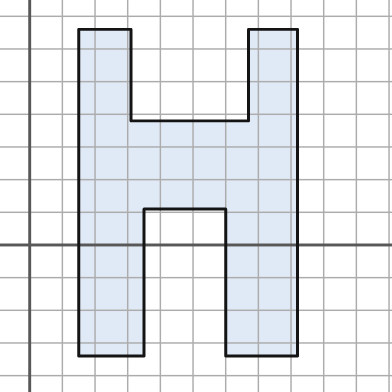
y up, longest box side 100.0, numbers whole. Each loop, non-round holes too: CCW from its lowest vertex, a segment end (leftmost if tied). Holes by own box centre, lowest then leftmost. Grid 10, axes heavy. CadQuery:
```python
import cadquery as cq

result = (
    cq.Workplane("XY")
    .moveTo(15.0, -34.0)
    .lineTo(35.0, -34.0)
    .lineTo(35.0, 11.0)
    .lineTo(60.0, 11.0)
    .lineTo(60.0, -34.0)
    .lineTo(82.0, -34.0)
    .lineTo(82.0, 66.0)
    .lineTo(67.0, 66.0)
    .lineTo(67.0, 38.0)
    .lineTo(31.0, 38.0)
    .lineTo(31.0, 66.0)
    .lineTo(15.0, 66.0)
    .close()
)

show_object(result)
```